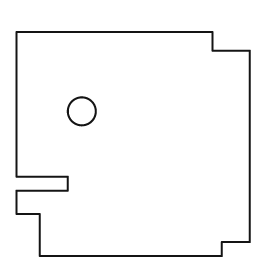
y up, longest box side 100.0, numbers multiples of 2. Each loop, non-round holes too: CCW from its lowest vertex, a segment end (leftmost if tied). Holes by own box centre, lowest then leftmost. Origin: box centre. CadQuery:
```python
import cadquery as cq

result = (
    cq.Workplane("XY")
    .moveTo(-40.0, -48.0)
    .lineTo(38.0, -48.0)
    .lineTo(38.0, -42.0)
    .lineTo(50.0, -42.0)
    .lineTo(50.0, 40.0)
    .lineTo(34.0, 40.0)
    .lineTo(34.0, 48.0)
    .lineTo(-50.0, 48.0)
    .lineTo(-50.0, -14.0)
    .lineTo(-28.0, -14.0)
    .lineTo(-28.0, -20.0)
    .lineTo(-50.0, -20.0)
    .lineTo(-50.0, -30.0)
    .lineTo(-40.0, -30.0)
    .close()
    .moveTo(-22.0, 14.0)
    .circle(6.0)
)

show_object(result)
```